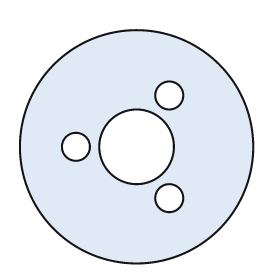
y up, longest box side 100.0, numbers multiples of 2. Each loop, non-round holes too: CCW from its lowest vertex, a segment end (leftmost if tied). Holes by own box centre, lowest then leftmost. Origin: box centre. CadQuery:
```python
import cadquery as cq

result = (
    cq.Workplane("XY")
    .moveTo(0.0, 0.0)
    .circle(50.0)
    .moveTo(14.0, -22.0)
    .circle(6.0)
    .moveTo(-26.0, 0.0)
    .circle(6.0)
    .moveTo(0.0, 0.0)
    .circle(16.0)
    .moveTo(14.0, 22.0)
    .circle(6.0)
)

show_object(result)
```